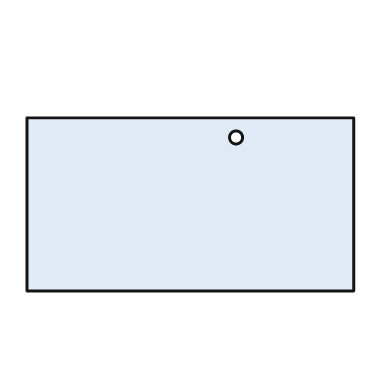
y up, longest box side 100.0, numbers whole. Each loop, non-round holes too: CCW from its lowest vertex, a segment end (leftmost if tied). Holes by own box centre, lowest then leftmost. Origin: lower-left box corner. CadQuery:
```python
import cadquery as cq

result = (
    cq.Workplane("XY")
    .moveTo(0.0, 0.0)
    .lineTo(100.0, 0.0)
    .lineTo(100.0, 53.0)
    .lineTo(0.0, 53.0)
    .close()
    .moveTo(64.0, 47.0)
    .circle(2.0)
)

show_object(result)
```